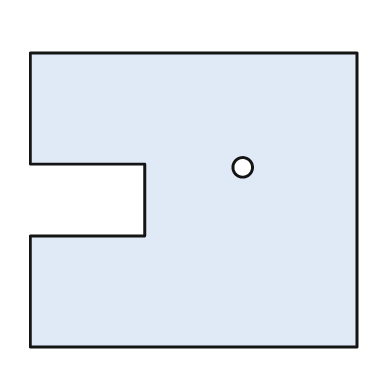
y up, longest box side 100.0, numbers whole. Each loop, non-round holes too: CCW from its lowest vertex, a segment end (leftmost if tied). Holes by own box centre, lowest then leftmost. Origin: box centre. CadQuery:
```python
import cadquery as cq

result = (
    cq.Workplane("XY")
    .moveTo(-50.0, -45.0)
    .lineTo(50.0, -45.0)
    .lineTo(50.0, 45.0)
    .lineTo(-50.0, 45.0)
    .lineTo(-50.0, 11.0)
    .lineTo(-15.0, 11.0)
    .lineTo(-15.0, -11.0)
    .lineTo(-50.0, -11.0)
    .close()
    .moveTo(15.0, 10.0)
    .circle(3.0)
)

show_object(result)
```